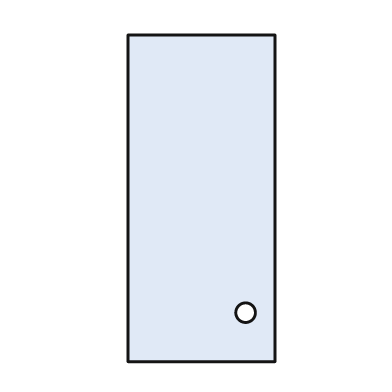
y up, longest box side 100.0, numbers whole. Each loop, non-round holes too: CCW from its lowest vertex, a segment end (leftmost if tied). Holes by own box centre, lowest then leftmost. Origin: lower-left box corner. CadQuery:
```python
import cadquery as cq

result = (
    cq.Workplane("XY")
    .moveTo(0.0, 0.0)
    .lineTo(45.0, 0.0)
    .lineTo(45.0, 100.0)
    .lineTo(0.0, 100.0)
    .close()
    .moveTo(36.0, 15.0)
    .circle(3.0)
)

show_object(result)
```